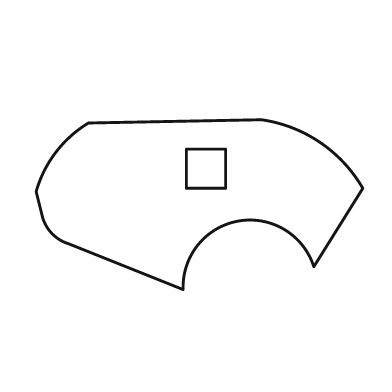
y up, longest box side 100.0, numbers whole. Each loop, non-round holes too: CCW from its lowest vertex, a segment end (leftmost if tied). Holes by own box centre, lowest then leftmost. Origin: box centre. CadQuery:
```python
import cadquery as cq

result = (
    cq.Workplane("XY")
    .moveTo(-5.0, -26.0)
    .threePointArc((12.0, -5.0), (35.0, -19.0))
    .lineTo(50.0, 5.0)
    .threePointArc((37.0, 19.0), (19.0, 26.0))
    .lineTo(-34.0, 25.0)
    .threePointArc((-44.0, 16.0), (-50.0, 4.0))
    .lineTo(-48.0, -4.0)
    .threePointArc((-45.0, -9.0), (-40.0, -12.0))
    .close()
    .moveTo(-4.0, 5.0)
    .lineTo(8.0, 5.0)
    .lineTo(8.0, 17.0)
    .lineTo(-4.0, 17.0)
    .close()
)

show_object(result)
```